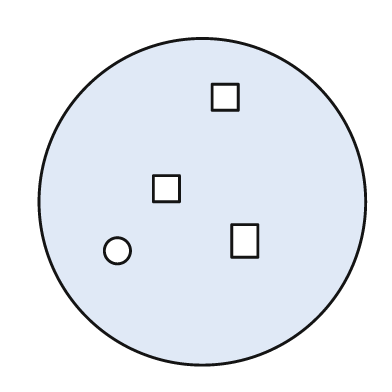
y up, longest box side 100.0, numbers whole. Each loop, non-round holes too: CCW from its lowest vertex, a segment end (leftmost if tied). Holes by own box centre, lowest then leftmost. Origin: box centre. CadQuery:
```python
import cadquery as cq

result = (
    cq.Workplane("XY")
    .moveTo(0.0, 0.0)
    .circle(50.0)
    .moveTo(-26.0, -15.0)
    .circle(4.0)
    .moveTo(9.0, -17.0)
    .lineTo(17.0, -17.0)
    .lineTo(17.0, -7.0)
    .lineTo(9.0, -7.0)
    .close()
    .moveTo(-15.0, 0.0)
    .lineTo(-7.0, 0.0)
    .lineTo(-7.0, 8.0)
    .lineTo(-15.0, 8.0)
    .close()
    .moveTo(3.0, 28.0)
    .lineTo(11.0, 28.0)
    .lineTo(11.0, 36.0)
    .lineTo(3.0, 36.0)
    .close()
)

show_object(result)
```